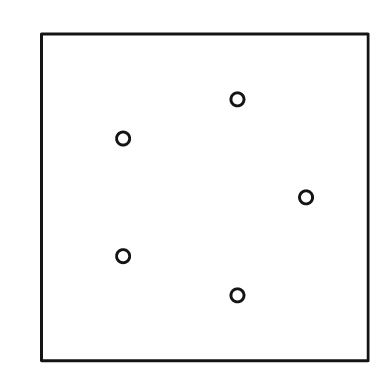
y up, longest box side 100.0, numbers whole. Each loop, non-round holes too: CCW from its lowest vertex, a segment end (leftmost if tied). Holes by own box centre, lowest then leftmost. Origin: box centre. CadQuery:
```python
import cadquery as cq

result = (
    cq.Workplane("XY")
    .moveTo(-50.0, -50.0)
    .lineTo(50.0, -50.0)
    .lineTo(50.0, 50.0)
    .lineTo(-50.0, 50.0)
    .close()
    .moveTo(10.0, -30.0)
    .circle(2.0)
    .moveTo(-25.0, -18.0)
    .circle(2.0)
    .moveTo(31.0, 0.0)
    .circle(2.0)
    .moveTo(-25.0, 18.0)
    .circle(2.0)
    .moveTo(10.0, 30.0)
    .circle(2.0)
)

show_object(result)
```